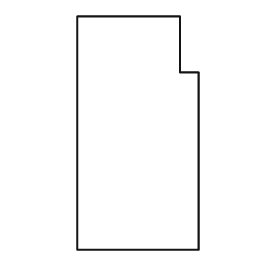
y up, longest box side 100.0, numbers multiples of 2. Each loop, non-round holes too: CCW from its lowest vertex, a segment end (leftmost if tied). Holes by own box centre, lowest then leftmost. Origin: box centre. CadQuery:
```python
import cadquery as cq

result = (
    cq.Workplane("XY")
    .moveTo(-26.0, -50.0)
    .lineTo(26.0, -50.0)
    .lineTo(26.0, 26.0)
    .lineTo(18.0, 26.0)
    .lineTo(18.0, 50.0)
    .lineTo(-26.0, 50.0)
    .close()
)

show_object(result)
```